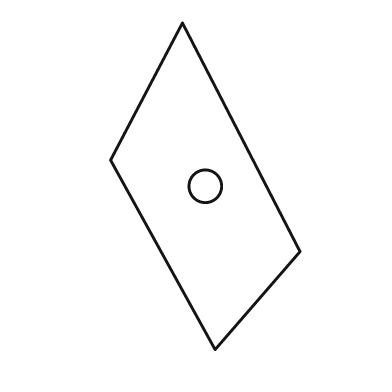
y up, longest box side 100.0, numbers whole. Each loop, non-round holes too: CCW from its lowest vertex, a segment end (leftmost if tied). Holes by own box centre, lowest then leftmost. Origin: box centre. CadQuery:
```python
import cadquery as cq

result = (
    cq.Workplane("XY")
    .moveTo(3.0, -50.0)
    .lineTo(29.0, -20.0)
    .lineTo(-7.0, 50.0)
    .lineTo(-29.0, 8.0)
    .close()
    .moveTo(0.0, 0.0)
    .circle(5.0)
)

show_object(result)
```